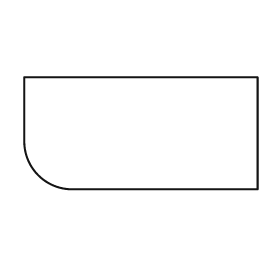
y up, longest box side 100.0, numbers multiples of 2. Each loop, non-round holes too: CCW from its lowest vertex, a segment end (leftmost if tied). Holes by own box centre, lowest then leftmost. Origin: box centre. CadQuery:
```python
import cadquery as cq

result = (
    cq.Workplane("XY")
    .moveTo(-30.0, -24.0)
    .lineTo(50.0, -24.0)
    .lineTo(50.0, 24.0)
    .lineTo(-50.0, 24.0)
    .lineTo(-50.0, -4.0)
    .threePointArc((-44.0, -18.0), (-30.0, -24.0))
    .close()
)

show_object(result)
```